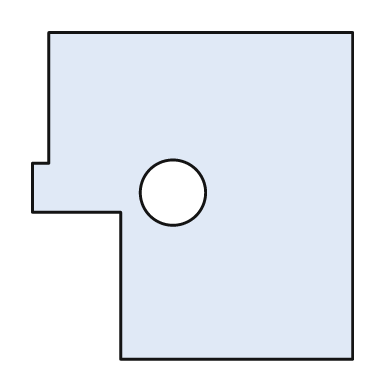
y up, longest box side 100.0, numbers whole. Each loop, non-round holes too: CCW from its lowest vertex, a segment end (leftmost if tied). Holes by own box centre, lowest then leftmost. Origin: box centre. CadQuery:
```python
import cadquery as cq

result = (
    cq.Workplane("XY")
    .moveTo(-22.0, -50.0)
    .lineTo(49.0, -50.0)
    .lineTo(49.0, 50.0)
    .lineTo(-44.0, 50.0)
    .lineTo(-44.0, 10.0)
    .lineTo(-49.0, 10.0)
    .lineTo(-49.0, -5.0)
    .lineTo(-22.0, -5.0)
    .close()
    .moveTo(-6.0, 1.0)
    .circle(10.0)
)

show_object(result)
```